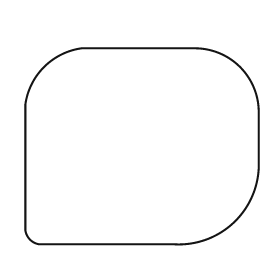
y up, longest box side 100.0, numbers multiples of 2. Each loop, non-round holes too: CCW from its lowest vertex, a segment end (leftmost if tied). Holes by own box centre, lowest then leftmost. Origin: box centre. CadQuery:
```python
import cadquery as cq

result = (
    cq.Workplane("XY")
    .moveTo(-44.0, -42.0)
    .lineTo(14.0, -42.0)
    .threePointArc((40.0, -32.0), (50.0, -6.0))
    .lineTo(50.0, 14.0)
    .threePointArc((42.0, 34.0), (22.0, 42.0))
    .lineTo(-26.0, 42.0)
    .threePointArc((-42.0, 34.0), (-50.0, 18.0))
    .lineTo(-50.0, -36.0)
    .threePointArc((-48.0, -40.0), (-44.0, -42.0))
    .close()
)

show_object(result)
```